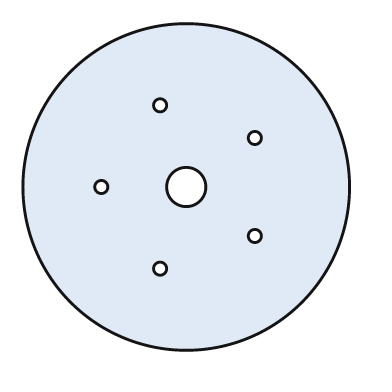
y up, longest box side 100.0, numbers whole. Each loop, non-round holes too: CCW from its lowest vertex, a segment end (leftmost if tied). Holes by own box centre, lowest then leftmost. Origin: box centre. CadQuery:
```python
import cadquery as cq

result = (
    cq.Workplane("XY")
    .moveTo(0.0, 0.0)
    .circle(50.0)
    .moveTo(-8.0, -25.0)
    .circle(2.0)
    .moveTo(21.0, -15.0)
    .circle(2.0)
    .moveTo(-26.0, 0.0)
    .circle(2.0)
    .moveTo(0.0, 0.0)
    .circle(6.0)
    .moveTo(21.0, 15.0)
    .circle(2.0)
    .moveTo(-8.0, 25.0)
    .circle(2.0)
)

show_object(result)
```